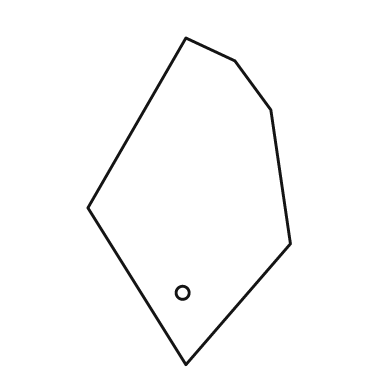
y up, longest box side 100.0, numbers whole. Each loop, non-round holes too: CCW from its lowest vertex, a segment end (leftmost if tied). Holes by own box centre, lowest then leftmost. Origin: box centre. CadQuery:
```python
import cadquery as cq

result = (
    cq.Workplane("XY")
    .moveTo(-1.0, -50.0)
    .lineTo(31.0, -13.0)
    .lineTo(25.0, 28.0)
    .lineTo(14.0, 43.0)
    .lineTo(-1.0, 50.0)
    .lineTo(-31.0, -2.0)
    .close()
    .moveTo(-2.0, -28.0)
    .circle(2.0)
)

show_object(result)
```